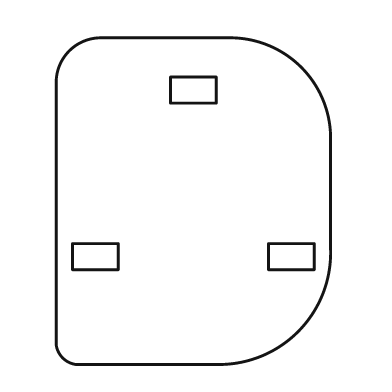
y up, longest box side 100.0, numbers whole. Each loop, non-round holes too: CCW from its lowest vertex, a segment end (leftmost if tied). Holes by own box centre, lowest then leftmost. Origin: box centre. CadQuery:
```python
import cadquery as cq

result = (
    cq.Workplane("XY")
    .moveTo(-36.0, -50.0)
    .lineTo(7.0, -50.0)
    .threePointArc((32.0, -40.0), (42.0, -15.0))
    .lineTo(42.0, 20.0)
    .threePointArc((33.0, 41.0), (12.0, 50.0))
    .lineTo(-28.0, 50.0)
    .threePointArc((-38.0, 46.0), (-42.0, 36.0))
    .lineTo(-42.0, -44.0)
    .threePointArc((-40.0, -48.0), (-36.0, -50.0))
    .close()
    .moveTo(-37.0, -21.0)
    .lineTo(-23.0, -21.0)
    .lineTo(-23.0, -13.0)
    .lineTo(-37.0, -13.0)
    .close()
    .moveTo(23.0, -21.0)
    .lineTo(37.0, -21.0)
    .lineTo(37.0, -13.0)
    .lineTo(23.0, -13.0)
    .close()
    .moveTo(-7.0, 30.0)
    .lineTo(7.0, 30.0)
    .lineTo(7.0, 38.0)
    .lineTo(-7.0, 38.0)
    .close()
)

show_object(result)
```